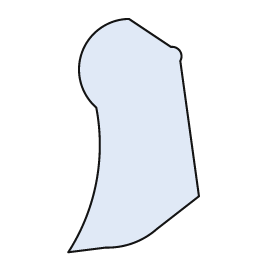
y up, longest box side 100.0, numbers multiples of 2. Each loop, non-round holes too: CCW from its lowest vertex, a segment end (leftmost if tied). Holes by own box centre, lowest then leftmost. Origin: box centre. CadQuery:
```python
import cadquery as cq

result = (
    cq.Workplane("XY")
    .moveTo(-28.0, -50.0)
    .lineTo(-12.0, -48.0)
    .threePointArc((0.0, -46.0), (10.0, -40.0))
    .lineTo(28.0, -26.0)
    .lineTo(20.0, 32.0)
    .threePointArc((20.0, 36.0), (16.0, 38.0))
    .lineTo(-2.0, 50.0)
    .threePointArc((-22.0, 36.0), (-16.0, 12.0))
    .threePointArc((-16.0, -20.0), (-28.0, -50.0))
    .close()
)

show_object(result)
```